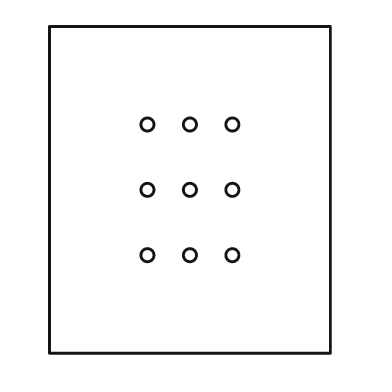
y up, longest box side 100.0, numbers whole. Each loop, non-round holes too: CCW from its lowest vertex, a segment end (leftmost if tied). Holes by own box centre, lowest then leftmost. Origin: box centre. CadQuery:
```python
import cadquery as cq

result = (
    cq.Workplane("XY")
    .moveTo(-43.0, -50.0)
    .lineTo(43.0, -50.0)
    .lineTo(43.0, 50.0)
    .lineTo(-43.0, 50.0)
    .close()
    .moveTo(-13.0, -20.0)
    .circle(2.0)
    .moveTo(0.0, -20.0)
    .circle(2.0)
    .moveTo(13.0, -20.0)
    .circle(2.0)
    .moveTo(-13.0, 0.0)
    .circle(2.0)
    .moveTo(0.0, 0.0)
    .circle(2.0)
    .moveTo(13.0, 0.0)
    .circle(2.0)
    .moveTo(-13.0, 20.0)
    .circle(2.0)
    .moveTo(0.0, 20.0)
    .circle(2.0)
    .moveTo(13.0, 20.0)
    .circle(2.0)
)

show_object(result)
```